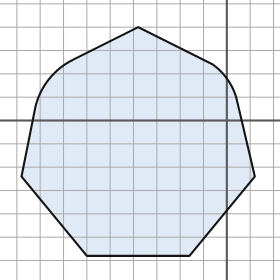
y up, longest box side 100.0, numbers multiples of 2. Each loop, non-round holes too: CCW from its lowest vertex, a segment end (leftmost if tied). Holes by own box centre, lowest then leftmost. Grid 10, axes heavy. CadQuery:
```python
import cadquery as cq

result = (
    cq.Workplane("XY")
    .moveTo(-60.0, -58.0)
    .lineTo(-16.0, -58.0)
    .lineTo(12.0, -24.0)
    .lineTo(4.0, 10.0)
    .threePointArc((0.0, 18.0), (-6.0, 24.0))
    .lineTo(-38.0, 40.0)
    .lineTo(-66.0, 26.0)
    .threePointArc((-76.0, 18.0), (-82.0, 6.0))
    .lineTo(-88.0, -24.0)
    .close()
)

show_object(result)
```